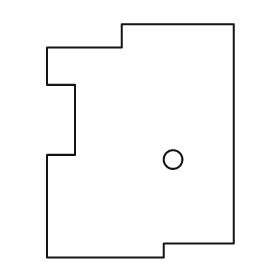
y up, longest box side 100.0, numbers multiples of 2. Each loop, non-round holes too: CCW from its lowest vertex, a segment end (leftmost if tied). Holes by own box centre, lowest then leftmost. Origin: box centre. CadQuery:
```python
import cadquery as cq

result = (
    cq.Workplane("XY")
    .moveTo(-40.0, -50.0)
    .lineTo(10.0, -50.0)
    .lineTo(10.0, -44.0)
    .lineTo(40.0, -44.0)
    .lineTo(40.0, 50.0)
    .lineTo(-8.0, 50.0)
    .lineTo(-8.0, 40.0)
    .lineTo(-40.0, 40.0)
    .lineTo(-40.0, 24.0)
    .lineTo(-28.0, 24.0)
    .lineTo(-28.0, -6.0)
    .lineTo(-40.0, -6.0)
    .close()
    .moveTo(14.0, -8.0)
    .circle(4.0)
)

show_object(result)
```